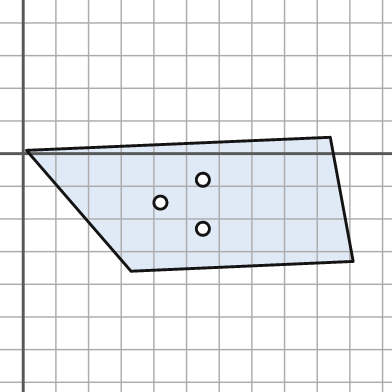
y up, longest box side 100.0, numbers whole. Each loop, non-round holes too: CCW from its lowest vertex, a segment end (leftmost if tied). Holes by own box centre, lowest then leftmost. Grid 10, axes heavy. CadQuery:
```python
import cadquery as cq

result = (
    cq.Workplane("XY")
    .moveTo(33.0, -36.0)
    .lineTo(101.0, -33.0)
    .lineTo(94.0, 5.0)
    .lineTo(1.0, 1.0)
    .close()
    .moveTo(55.0, -23.0)
    .circle(2.0)
    .moveTo(42.0, -15.0)
    .circle(2.0)
    .moveTo(55.0, -8.0)
    .circle(2.0)
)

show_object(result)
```